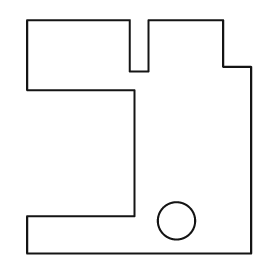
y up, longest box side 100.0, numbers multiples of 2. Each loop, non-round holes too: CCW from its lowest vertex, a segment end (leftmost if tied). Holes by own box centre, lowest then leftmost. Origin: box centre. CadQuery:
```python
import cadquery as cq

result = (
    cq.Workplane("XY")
    .moveTo(-48.0, -50.0)
    .lineTo(48.0, -50.0)
    .lineTo(48.0, 30.0)
    .lineTo(36.0, 30.0)
    .lineTo(36.0, 50.0)
    .lineTo(4.0, 50.0)
    .lineTo(4.0, 28.0)
    .lineTo(-4.0, 28.0)
    .lineTo(-4.0, 50.0)
    .lineTo(-48.0, 50.0)
    .lineTo(-48.0, 20.0)
    .lineTo(-2.0, 20.0)
    .lineTo(-2.0, -34.0)
    .lineTo(-48.0, -34.0)
    .close()
    .moveTo(16.0, -36.0)
    .circle(8.0)
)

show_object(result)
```